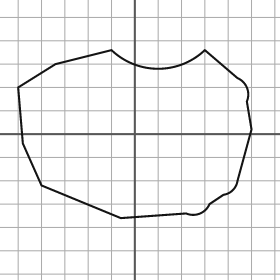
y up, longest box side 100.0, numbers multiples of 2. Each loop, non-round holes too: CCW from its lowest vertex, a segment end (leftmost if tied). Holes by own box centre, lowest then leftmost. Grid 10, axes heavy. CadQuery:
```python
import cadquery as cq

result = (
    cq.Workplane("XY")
    .moveTo(-6.0, -36.0)
    .lineTo(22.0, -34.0)
    .threePointArc((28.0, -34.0), (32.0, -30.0))
    .lineTo(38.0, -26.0)
    .threePointArc((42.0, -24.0), (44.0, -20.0))
    .lineTo(50.0, 2.0)
    .lineTo(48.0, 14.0)
    .threePointArc((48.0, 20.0), (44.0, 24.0))
    .lineTo(30.0, 36.0)
    .threePointArc((10.0, 28.0), (-10.0, 36.0))
    .lineTo(-34.0, 30.0)
    .lineTo(-50.0, 20.0)
    .lineTo(-48.0, -4.0)
    .lineTo(-40.0, -22.0)
    .close()
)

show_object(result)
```